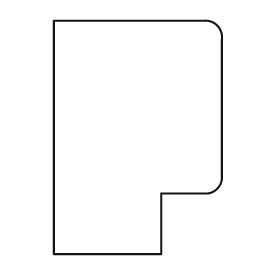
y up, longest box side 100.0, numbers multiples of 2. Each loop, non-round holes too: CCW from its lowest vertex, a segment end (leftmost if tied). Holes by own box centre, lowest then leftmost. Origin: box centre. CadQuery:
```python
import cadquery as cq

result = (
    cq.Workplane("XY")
    .moveTo(-36.0, -50.0)
    .lineTo(10.0, -50.0)
    .lineTo(10.0, -24.0)
    .lineTo(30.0, -24.0)
    .threePointArc((34.0, -22.0), (36.0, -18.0))
    .lineTo(36.0, 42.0)
    .threePointArc((34.0, 48.0), (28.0, 50.0))
    .lineTo(-36.0, 50.0)
    .close()
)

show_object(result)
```